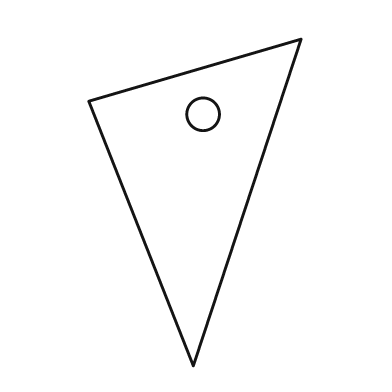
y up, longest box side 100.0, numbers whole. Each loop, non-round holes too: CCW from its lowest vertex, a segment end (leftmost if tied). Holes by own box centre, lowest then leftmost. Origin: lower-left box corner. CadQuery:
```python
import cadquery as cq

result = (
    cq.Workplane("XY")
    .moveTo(32.0, 0.0)
    .lineTo(65.0, 100.0)
    .lineTo(0.0, 81.0)
    .close()
    .moveTo(35.0, 77.0)
    .circle(5.0)
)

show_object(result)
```